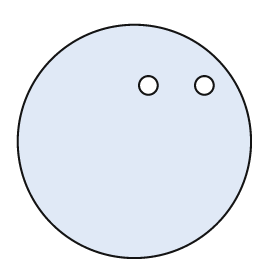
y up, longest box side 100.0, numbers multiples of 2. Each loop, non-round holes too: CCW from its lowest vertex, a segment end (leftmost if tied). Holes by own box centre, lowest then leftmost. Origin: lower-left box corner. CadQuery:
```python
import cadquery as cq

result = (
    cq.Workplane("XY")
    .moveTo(50.0, 50.0)
    .circle(50.0)
    .moveTo(56.0, 74.0)
    .circle(4.0)
    .moveTo(80.0, 74.0)
    .circle(4.0)
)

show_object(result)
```